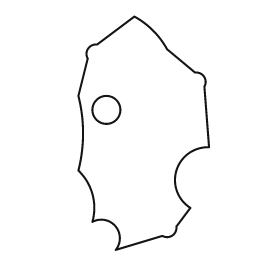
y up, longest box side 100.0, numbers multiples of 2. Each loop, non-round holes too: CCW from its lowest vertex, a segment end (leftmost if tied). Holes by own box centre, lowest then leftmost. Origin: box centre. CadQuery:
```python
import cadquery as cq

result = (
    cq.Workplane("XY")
    .moveTo(-12.0, -50.0)
    .lineTo(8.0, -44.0)
    .threePointArc((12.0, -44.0), (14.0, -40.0))
    .lineTo(20.0, -32.0)
    .threePointArc((14.0, -16.0), (28.0, -6.0))
    .lineTo(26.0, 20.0)
    .threePointArc((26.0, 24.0), (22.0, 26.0))
    .lineTo(10.0, 36.0)
    .threePointArc((4.0, 44.0), (-4.0, 50.0))
    .lineTo(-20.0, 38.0)
    .threePointArc((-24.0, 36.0), (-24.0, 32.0))
    .lineTo(-28.0, 16.0)
    .threePointArc((-26.0, 0.0), (-28.0, -16.0))
    .threePointArc((-22.0, -26.0), (-22.0, -38.0))
    .threePointArc((-12.0, -40.0), (-12.0, -50.0))
    .close()
    .moveTo(-16.0, 10.0)
    .circle(6.0)
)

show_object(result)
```